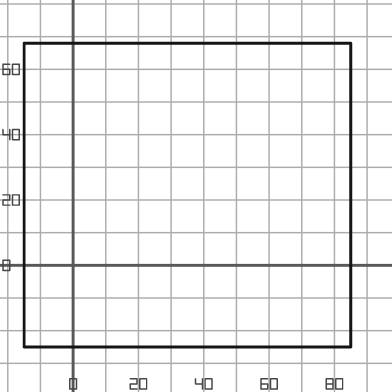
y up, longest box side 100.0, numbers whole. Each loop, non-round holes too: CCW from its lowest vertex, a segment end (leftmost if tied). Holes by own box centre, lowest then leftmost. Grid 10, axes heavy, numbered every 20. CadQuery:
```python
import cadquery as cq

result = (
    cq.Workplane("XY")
    .moveTo(-15.0, -25.0)
    .lineTo(85.0, -25.0)
    .lineTo(85.0, 68.0)
    .lineTo(-15.0, 68.0)
    .close()
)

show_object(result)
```